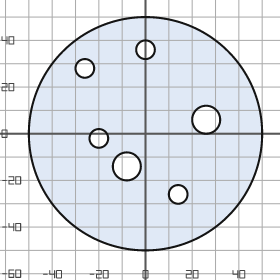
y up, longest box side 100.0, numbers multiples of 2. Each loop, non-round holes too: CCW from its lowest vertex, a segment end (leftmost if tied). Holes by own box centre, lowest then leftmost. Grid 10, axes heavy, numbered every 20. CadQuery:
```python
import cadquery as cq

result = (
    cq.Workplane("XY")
    .moveTo(0.0, 0.0)
    .circle(50.0)
    .moveTo(14.0, -26.0)
    .circle(4.0)
    .moveTo(-8.0, -14.0)
    .circle(6.0)
    .moveTo(-20.0, -2.0)
    .circle(4.0)
    .moveTo(26.0, 6.0)
    .circle(6.0)
    .moveTo(-26.0, 28.0)
    .circle(4.0)
    .moveTo(0.0, 36.0)
    .circle(4.0)
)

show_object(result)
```